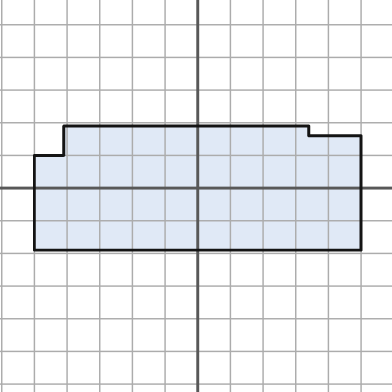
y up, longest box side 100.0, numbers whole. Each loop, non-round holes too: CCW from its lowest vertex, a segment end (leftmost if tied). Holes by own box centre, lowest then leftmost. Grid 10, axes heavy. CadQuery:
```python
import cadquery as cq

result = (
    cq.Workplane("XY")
    .moveTo(-50.0, -19.0)
    .lineTo(50.0, -19.0)
    .lineTo(50.0, 16.0)
    .lineTo(34.0, 16.0)
    .lineTo(34.0, 19.0)
    .lineTo(-41.0, 19.0)
    .lineTo(-41.0, 10.0)
    .lineTo(-50.0, 10.0)
    .close()
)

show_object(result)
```